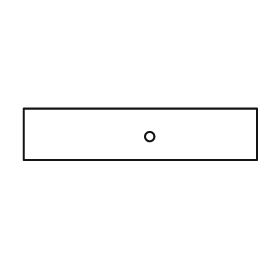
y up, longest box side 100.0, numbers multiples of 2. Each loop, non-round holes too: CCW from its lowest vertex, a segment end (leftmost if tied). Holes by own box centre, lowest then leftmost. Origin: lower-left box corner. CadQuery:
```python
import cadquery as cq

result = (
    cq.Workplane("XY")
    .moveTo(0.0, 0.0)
    .lineTo(100.0, 0.0)
    .lineTo(100.0, 22.0)
    .lineTo(0.0, 22.0)
    .close()
    .moveTo(54.0, 10.0)
    .circle(2.0)
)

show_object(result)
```